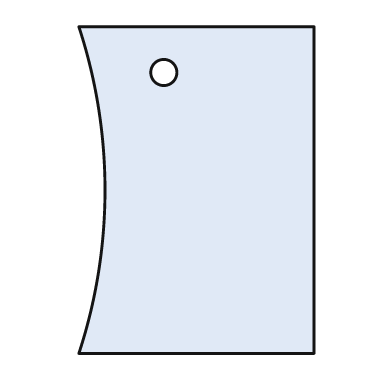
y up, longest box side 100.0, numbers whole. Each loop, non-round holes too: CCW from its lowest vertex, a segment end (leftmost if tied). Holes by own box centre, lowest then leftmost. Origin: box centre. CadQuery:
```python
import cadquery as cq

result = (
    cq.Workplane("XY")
    .moveTo(-36.0, -50.0)
    .lineTo(36.0, -50.0)
    .lineTo(36.0, 50.0)
    .lineTo(-36.0, 50.0)
    .threePointArc((-28.0, 0.0), (-36.0, -50.0))
    .close()
    .moveTo(-10.0, 36.0)
    .circle(4.0)
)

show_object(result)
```